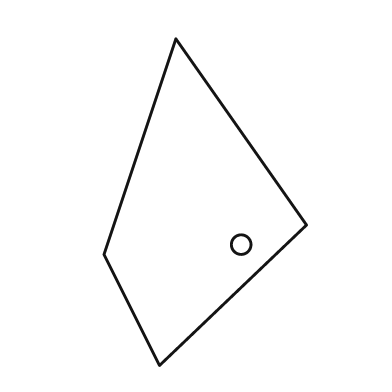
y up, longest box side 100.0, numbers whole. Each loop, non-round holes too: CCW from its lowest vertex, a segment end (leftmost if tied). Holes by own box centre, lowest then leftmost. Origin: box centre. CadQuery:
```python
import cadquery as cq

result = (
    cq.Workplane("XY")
    .moveTo(-14.0, -50.0)
    .lineTo(31.0, -7.0)
    .lineTo(-9.0, 50.0)
    .lineTo(-31.0, -16.0)
    .close()
    .moveTo(11.0, -13.0)
    .circle(3.0)
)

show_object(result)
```